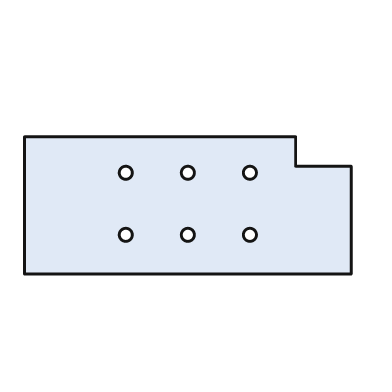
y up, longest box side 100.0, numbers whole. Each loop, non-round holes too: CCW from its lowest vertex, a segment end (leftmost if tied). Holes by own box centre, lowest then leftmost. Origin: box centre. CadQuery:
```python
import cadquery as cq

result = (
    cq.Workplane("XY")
    .moveTo(-50.0, -21.0)
    .lineTo(50.0, -21.0)
    .lineTo(50.0, 12.0)
    .lineTo(33.0, 12.0)
    .lineTo(33.0, 21.0)
    .lineTo(-50.0, 21.0)
    .close()
    .moveTo(-19.0, -9.0)
    .circle(2.0)
    .moveTo(0.0, -9.0)
    .circle(2.0)
    .moveTo(19.0, -9.0)
    .circle(2.0)
    .moveTo(-19.0, 10.0)
    .circle(2.0)
    .moveTo(0.0, 10.0)
    .circle(2.0)
    .moveTo(19.0, 10.0)
    .circle(2.0)
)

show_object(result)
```